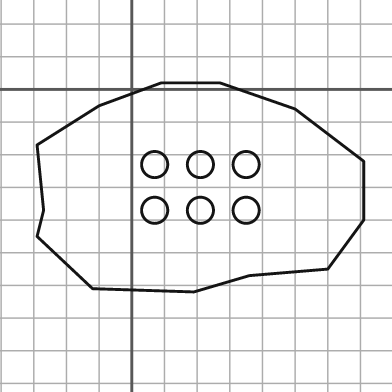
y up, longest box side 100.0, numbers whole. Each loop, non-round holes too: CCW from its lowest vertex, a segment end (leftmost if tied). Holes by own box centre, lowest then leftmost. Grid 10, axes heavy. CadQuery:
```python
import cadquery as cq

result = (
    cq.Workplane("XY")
    .moveTo(19.0, -62.0)
    .lineTo(36.0, -57.0)
    .lineTo(60.0, -55.0)
    .lineTo(71.0, -40.0)
    .lineTo(71.0, -22.0)
    .lineTo(50.0, -6.0)
    .lineTo(27.0, 2.0)
    .lineTo(9.0, 2.0)
    .lineTo(-10.0, -5.0)
    .lineTo(-29.0, -17.0)
    .lineTo(-27.0, -37.0)
    .lineTo(-29.0, -45.0)
    .lineTo(-12.0, -61.0)
    .close()
    .moveTo(7.0, -37.0)
    .circle(4.0)
    .moveTo(21.0, -37.0)
    .circle(4.0)
    .moveTo(35.0, -37.0)
    .circle(4.0)
    .moveTo(7.0, -23.0)
    .circle(4.0)
    .moveTo(21.0, -23.0)
    .circle(4.0)
    .moveTo(35.0, -23.0)
    .circle(4.0)
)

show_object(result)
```